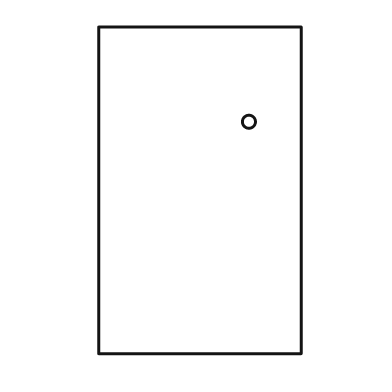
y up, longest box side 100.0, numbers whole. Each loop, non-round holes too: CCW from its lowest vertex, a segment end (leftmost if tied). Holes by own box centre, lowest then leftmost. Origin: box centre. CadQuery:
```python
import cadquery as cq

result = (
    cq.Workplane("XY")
    .moveTo(-31.0, -50.0)
    .lineTo(31.0, -50.0)
    .lineTo(31.0, 50.0)
    .lineTo(-31.0, 50.0)
    .close()
    .moveTo(15.0, 21.0)
    .circle(2.0)
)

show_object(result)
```